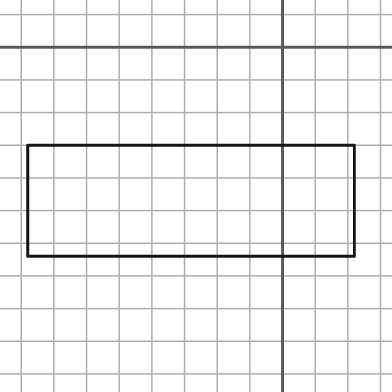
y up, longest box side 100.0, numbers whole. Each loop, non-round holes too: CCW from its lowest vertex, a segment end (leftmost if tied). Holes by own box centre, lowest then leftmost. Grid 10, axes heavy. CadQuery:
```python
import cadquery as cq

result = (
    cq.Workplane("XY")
    .moveTo(-78.0, -64.0)
    .lineTo(22.0, -64.0)
    .lineTo(22.0, -30.0)
    .lineTo(-78.0, -30.0)
    .close()
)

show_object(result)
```